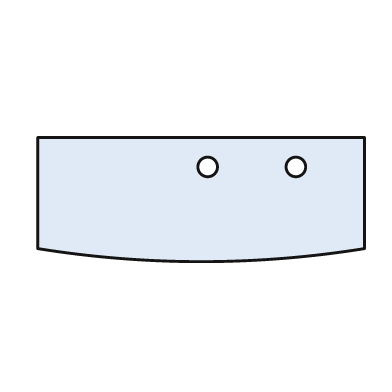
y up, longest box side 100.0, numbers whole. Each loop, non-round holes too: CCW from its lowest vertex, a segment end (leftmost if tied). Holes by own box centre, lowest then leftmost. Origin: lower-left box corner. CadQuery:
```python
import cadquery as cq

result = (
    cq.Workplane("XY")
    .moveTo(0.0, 4.0)
    .threePointArc((50.0, 0.0), (100.0, 4.0))
    .lineTo(100.0, 38.0)
    .lineTo(0.0, 38.0)
    .close()
    .moveTo(52.0, 29.0)
    .circle(3.0)
    .moveTo(79.0, 29.0)
    .circle(3.0)
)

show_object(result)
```